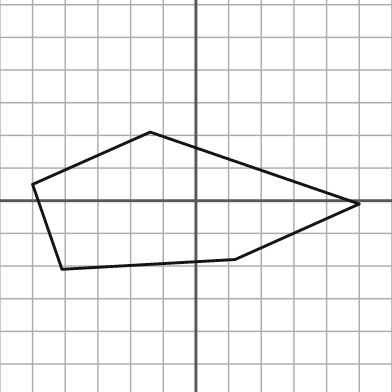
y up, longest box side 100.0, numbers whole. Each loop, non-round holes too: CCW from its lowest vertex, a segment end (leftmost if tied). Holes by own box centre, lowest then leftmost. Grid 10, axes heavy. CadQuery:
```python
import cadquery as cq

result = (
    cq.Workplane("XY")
    .moveTo(-41.0, -21.0)
    .lineTo(12.0, -18.0)
    .lineTo(50.0, -1.0)
    .lineTo(-14.0, 21.0)
    .lineTo(-50.0, 5.0)
    .close()
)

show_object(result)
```